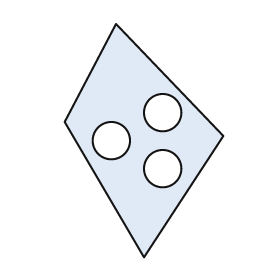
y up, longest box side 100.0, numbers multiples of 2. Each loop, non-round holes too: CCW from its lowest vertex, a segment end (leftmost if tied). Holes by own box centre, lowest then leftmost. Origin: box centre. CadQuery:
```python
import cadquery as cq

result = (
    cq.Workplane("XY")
    .moveTo(0.0, -50.0)
    .lineTo(34.0, 2.0)
    .lineTo(-12.0, 50.0)
    .lineTo(-34.0, 8.0)
    .close()
    .moveTo(8.0, -12.0)
    .circle(8.0)
    .moveTo(-14.0, 0.0)
    .circle(8.0)
    .moveTo(8.0, 12.0)
    .circle(8.0)
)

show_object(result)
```